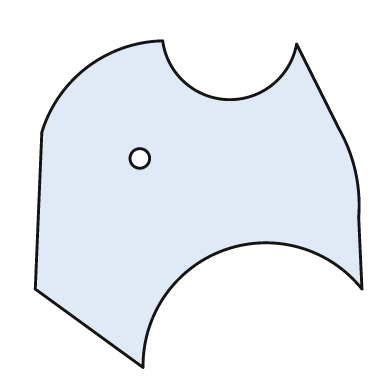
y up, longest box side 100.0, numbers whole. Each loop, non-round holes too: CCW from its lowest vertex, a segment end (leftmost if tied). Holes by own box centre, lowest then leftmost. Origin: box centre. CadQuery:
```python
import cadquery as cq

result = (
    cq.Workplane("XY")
    .moveTo(-17.0, -50.0)
    .threePointArc((8.0, -14.0), (50.0, -26.0))
    .lineTo(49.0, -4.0)
    .threePointArc((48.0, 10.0), (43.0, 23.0))
    .lineTo(30.0, 49.0)
    .threePointArc((9.0, 32.0), (-11.0, 50.0))
    .threePointArc((-34.0, 42.0), (-48.0, 22.0))
    .lineTo(-50.0, -26.0)
    .close()
    .moveTo(-18.0, 14.0)
    .circle(3.0)
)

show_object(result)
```